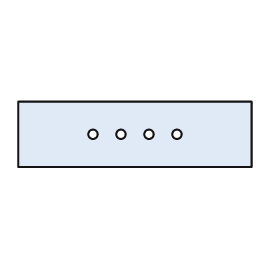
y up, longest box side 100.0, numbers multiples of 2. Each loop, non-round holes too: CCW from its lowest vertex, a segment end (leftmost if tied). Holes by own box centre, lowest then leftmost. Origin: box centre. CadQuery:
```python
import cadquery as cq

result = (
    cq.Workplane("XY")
    .moveTo(-50.0, -14.0)
    .lineTo(50.0, -14.0)
    .lineTo(50.0, 14.0)
    .lineTo(-50.0, 14.0)
    .close()
    .moveTo(-18.0, 0.0)
    .circle(2.0)
    .moveTo(-6.0, 0.0)
    .circle(2.0)
    .moveTo(6.0, 0.0)
    .circle(2.0)
    .moveTo(18.0, 0.0)
    .circle(2.0)
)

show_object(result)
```